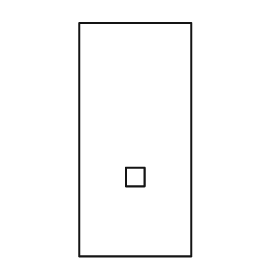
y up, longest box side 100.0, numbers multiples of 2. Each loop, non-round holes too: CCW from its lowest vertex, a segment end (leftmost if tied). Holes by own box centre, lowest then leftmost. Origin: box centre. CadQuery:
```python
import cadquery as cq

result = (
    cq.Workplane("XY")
    .moveTo(-24.0, -50.0)
    .lineTo(24.0, -50.0)
    .lineTo(24.0, 50.0)
    .lineTo(-24.0, 50.0)
    .close()
    .moveTo(-4.0, -20.0)
    .lineTo(4.0, -20.0)
    .lineTo(4.0, -12.0)
    .lineTo(-4.0, -12.0)
    .close()
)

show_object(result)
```